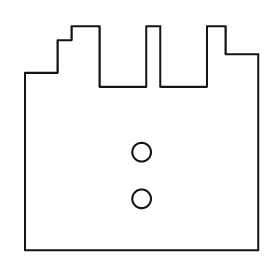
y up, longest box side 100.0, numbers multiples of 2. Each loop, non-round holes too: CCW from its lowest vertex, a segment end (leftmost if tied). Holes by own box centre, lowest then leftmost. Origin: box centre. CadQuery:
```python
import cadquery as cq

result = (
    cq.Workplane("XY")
    .moveTo(-50.0, -48.0)
    .lineTo(50.0, -48.0)
    .lineTo(50.0, 36.0)
    .lineTo(36.0, 36.0)
    .lineTo(36.0, 48.0)
    .lineTo(28.0, 48.0)
    .lineTo(28.0, 22.0)
    .lineTo(8.0, 22.0)
    .lineTo(8.0, 48.0)
    .lineTo(2.0, 48.0)
    .lineTo(2.0, 22.0)
    .lineTo(-18.0, 22.0)
    .lineTo(-18.0, 48.0)
    .lineTo(-30.0, 48.0)
    .lineTo(-30.0, 42.0)
    .lineTo(-36.0, 42.0)
    .lineTo(-36.0, 28.0)
    .lineTo(-50.0, 28.0)
    .close()
    .moveTo(0.0, -26.0)
    .circle(4.0)
    .moveTo(0.0, -6.0)
    .circle(4.0)
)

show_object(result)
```